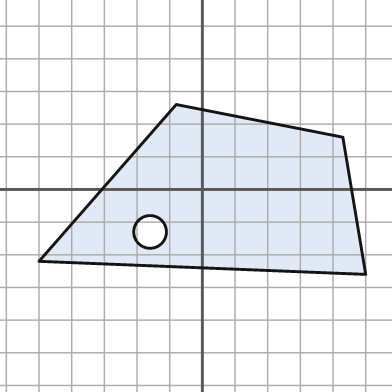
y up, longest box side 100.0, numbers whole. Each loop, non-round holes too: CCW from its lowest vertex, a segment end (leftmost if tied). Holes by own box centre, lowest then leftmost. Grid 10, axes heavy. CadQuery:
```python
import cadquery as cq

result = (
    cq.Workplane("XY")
    .moveTo(50.0, -26.0)
    .lineTo(43.0, 16.0)
    .lineTo(-8.0, 26.0)
    .lineTo(-50.0, -22.0)
    .close()
    .moveTo(-16.0, -13.0)
    .circle(5.0)
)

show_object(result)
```